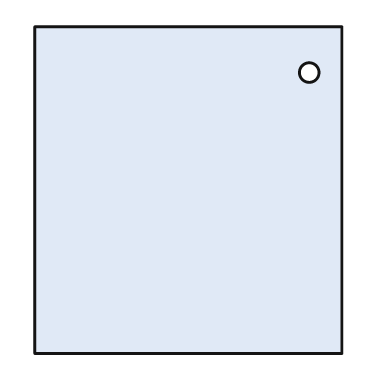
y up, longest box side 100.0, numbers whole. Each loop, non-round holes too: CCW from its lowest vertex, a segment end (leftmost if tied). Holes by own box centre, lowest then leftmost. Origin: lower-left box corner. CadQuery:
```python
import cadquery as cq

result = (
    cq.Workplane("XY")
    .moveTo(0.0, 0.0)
    .lineTo(94.0, 0.0)
    .lineTo(94.0, 100.0)
    .lineTo(0.0, 100.0)
    .close()
    .moveTo(84.0, 86.0)
    .circle(3.0)
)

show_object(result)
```